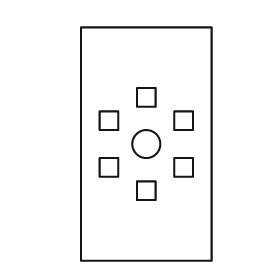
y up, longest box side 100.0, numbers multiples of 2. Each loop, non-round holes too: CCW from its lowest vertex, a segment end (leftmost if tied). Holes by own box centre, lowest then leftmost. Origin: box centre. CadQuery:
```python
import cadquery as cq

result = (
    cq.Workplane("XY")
    .moveTo(-28.0, -50.0)
    .lineTo(28.0, -50.0)
    .lineTo(28.0, 50.0)
    .lineTo(-28.0, 50.0)
    .close()
    .moveTo(-4.0, -24.0)
    .lineTo(4.0, -24.0)
    .lineTo(4.0, -16.0)
    .lineTo(-4.0, -16.0)
    .close()
    .moveTo(-20.0, -14.0)
    .lineTo(-12.0, -14.0)
    .lineTo(-12.0, -6.0)
    .lineTo(-20.0, -6.0)
    .close()
    .moveTo(12.0, -14.0)
    .lineTo(20.0, -14.0)
    .lineTo(20.0, -6.0)
    .lineTo(12.0, -6.0)
    .close()
    .moveTo(0.0, 0.0)
    .circle(6.0)
    .moveTo(-20.0, 6.0)
    .lineTo(-12.0, 6.0)
    .lineTo(-12.0, 14.0)
    .lineTo(-20.0, 14.0)
    .close()
    .moveTo(12.0, 6.0)
    .lineTo(20.0, 6.0)
    .lineTo(20.0, 14.0)
    .lineTo(12.0, 14.0)
    .close()
    .moveTo(-4.0, 16.0)
    .lineTo(4.0, 16.0)
    .lineTo(4.0, 24.0)
    .lineTo(-4.0, 24.0)
    .close()
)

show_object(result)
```